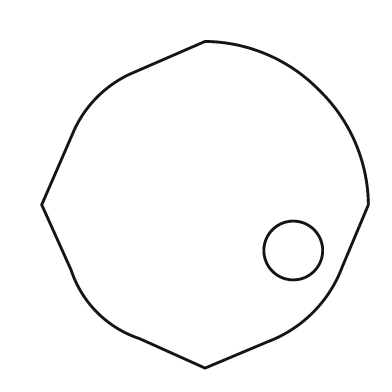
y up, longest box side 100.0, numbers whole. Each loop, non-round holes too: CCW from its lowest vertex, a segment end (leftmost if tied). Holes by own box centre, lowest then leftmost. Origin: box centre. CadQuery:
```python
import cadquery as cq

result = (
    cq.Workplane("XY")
    .moveTo(0.0, -50.0)
    .lineTo(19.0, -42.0)
    .threePointArc((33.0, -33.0), (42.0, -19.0))
    .lineTo(50.0, 0.0)
    .threePointArc((46.0, 19.0), (35.0, 35.0))
    .threePointArc((19.0, 46.0), (0.0, 50.0))
    .lineTo(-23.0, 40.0)
    .threePointArc((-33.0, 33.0), (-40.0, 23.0))
    .lineTo(-50.0, 0.0)
    .lineTo(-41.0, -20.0)
    .threePointArc((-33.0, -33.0), (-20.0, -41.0))
    .close()
    .moveTo(27.0, -14.0)
    .circle(9.0)
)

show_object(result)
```